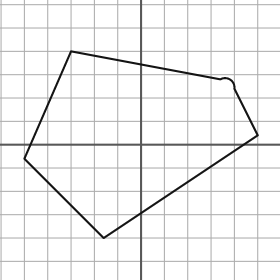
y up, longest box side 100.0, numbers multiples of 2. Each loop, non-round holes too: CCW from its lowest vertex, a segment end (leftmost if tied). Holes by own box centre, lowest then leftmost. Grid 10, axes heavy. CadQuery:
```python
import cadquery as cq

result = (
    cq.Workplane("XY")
    .moveTo(-16.0, -40.0)
    .lineTo(50.0, 4.0)
    .lineTo(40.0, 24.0)
    .threePointArc((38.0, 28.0), (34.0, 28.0))
    .lineTo(-30.0, 40.0)
    .lineTo(-50.0, -6.0)
    .close()
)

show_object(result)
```